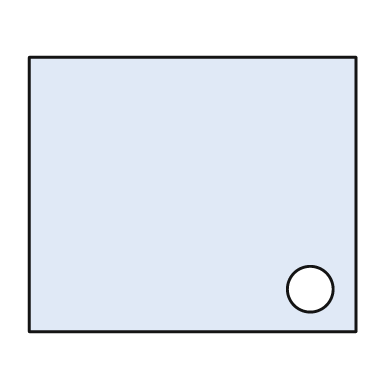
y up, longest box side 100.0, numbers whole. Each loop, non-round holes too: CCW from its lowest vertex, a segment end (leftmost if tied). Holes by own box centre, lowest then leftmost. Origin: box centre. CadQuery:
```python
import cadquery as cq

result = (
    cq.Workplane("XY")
    .moveTo(-50.0, -42.0)
    .lineTo(50.0, -42.0)
    .lineTo(50.0, 42.0)
    .lineTo(-50.0, 42.0)
    .close()
    .moveTo(36.0, -29.0)
    .circle(7.0)
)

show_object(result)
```